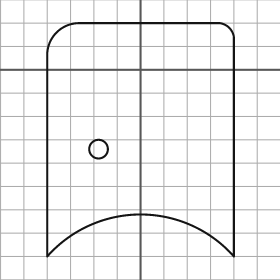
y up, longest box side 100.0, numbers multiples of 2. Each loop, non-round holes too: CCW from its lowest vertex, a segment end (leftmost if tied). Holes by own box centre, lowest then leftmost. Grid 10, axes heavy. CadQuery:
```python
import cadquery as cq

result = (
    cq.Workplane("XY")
    .moveTo(-40.0, -80.0)
    .threePointArc((0.0, -62.0), (40.0, -80.0))
    .lineTo(40.0, 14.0)
    .threePointArc((38.0, 18.0), (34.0, 20.0))
    .lineTo(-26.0, 20.0)
    .threePointArc((-36.0, 16.0), (-40.0, 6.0))
    .close()
    .moveTo(-18.0, -34.0)
    .circle(4.0)
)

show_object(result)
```